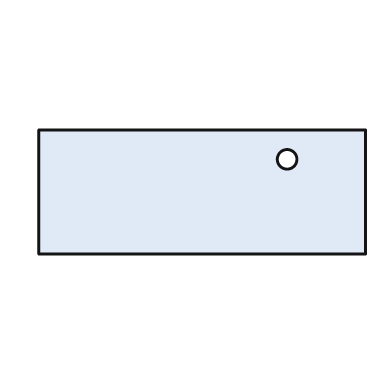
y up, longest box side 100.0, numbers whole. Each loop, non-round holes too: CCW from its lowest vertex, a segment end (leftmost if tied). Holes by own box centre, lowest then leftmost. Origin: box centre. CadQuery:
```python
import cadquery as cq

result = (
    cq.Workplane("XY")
    .moveTo(-50.0, -19.0)
    .lineTo(50.0, -19.0)
    .lineTo(50.0, 19.0)
    .lineTo(-50.0, 19.0)
    .close()
    .moveTo(26.0, 10.0)
    .circle(3.0)
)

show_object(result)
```